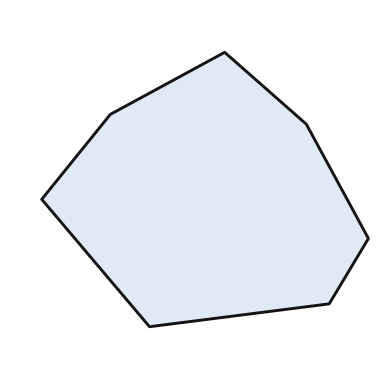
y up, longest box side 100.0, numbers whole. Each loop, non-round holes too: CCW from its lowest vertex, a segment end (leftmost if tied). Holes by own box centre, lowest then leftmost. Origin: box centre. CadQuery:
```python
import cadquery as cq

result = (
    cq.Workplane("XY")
    .moveTo(-17.0, -42.0)
    .lineTo(38.0, -35.0)
    .lineTo(50.0, -15.0)
    .lineTo(31.0, 20.0)
    .lineTo(6.0, 42.0)
    .lineTo(-29.0, 23.0)
    .lineTo(-50.0, -3.0)
    .close()
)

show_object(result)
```